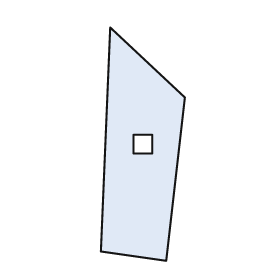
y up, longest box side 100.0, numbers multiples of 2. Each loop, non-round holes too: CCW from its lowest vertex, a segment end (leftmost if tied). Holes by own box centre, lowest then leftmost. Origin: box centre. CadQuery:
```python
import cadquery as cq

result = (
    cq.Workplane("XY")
    .moveTo(10.0, -50.0)
    .lineTo(18.0, 20.0)
    .lineTo(-14.0, 50.0)
    .lineTo(-18.0, -46.0)
    .close()
    .moveTo(-4.0, -4.0)
    .lineTo(4.0, -4.0)
    .lineTo(4.0, 4.0)
    .lineTo(-4.0, 4.0)
    .close()
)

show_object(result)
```